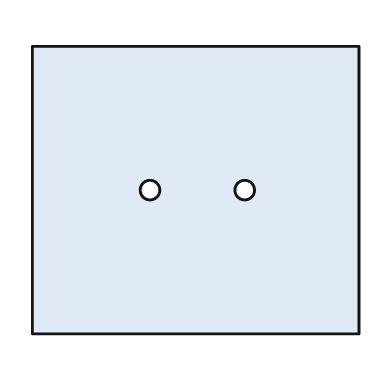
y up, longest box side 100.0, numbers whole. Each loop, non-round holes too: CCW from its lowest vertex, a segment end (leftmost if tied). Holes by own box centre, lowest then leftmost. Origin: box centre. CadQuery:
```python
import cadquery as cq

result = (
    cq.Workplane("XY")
    .moveTo(-50.0, -44.0)
    .lineTo(50.0, -44.0)
    .lineTo(50.0, 44.0)
    .lineTo(-50.0, 44.0)
    .close()
    .moveTo(-14.0, 0.0)
    .circle(3.0)
    .moveTo(15.0, 0.0)
    .circle(3.0)
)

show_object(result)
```